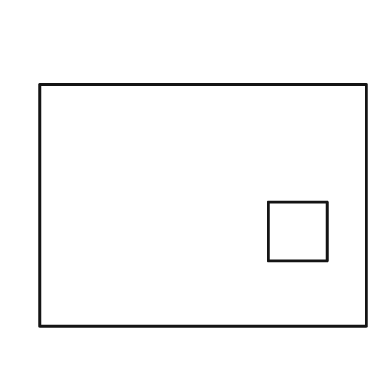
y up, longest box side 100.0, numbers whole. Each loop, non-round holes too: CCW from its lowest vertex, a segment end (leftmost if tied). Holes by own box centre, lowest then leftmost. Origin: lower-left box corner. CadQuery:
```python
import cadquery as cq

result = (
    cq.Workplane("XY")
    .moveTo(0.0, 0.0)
    .lineTo(100.0, 0.0)
    .lineTo(100.0, 74.0)
    .lineTo(0.0, 74.0)
    .close()
    .moveTo(70.0, 20.0)
    .lineTo(88.0, 20.0)
    .lineTo(88.0, 38.0)
    .lineTo(70.0, 38.0)
    .close()
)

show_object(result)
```